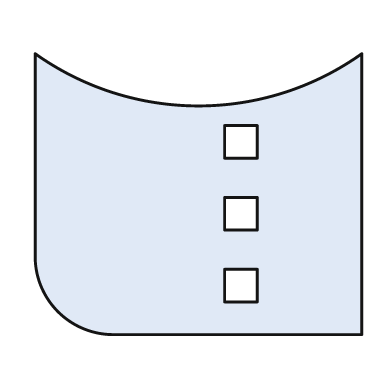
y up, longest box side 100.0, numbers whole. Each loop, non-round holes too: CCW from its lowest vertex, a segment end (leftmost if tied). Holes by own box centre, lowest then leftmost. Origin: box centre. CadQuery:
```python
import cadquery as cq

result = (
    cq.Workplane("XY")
    .moveTo(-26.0, -43.0)
    .lineTo(50.0, -43.0)
    .lineTo(50.0, 43.0)
    .threePointArc((0.0, 27.0), (-50.0, 43.0))
    .lineTo(-50.0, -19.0)
    .threePointArc((-43.0, -36.0), (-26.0, -43.0))
    .close()
    .moveTo(8.0, -33.0)
    .lineTo(18.0, -33.0)
    .lineTo(18.0, -23.0)
    .lineTo(8.0, -23.0)
    .close()
    .moveTo(8.0, -11.0)
    .lineTo(18.0, -11.0)
    .lineTo(18.0, -1.0)
    .lineTo(8.0, -1.0)
    .close()
    .moveTo(8.0, 11.0)
    .lineTo(18.0, 11.0)
    .lineTo(18.0, 21.0)
    .lineTo(8.0, 21.0)
    .close()
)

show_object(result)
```